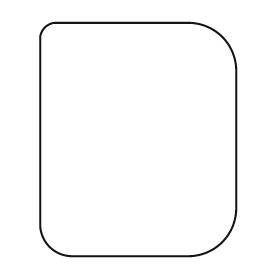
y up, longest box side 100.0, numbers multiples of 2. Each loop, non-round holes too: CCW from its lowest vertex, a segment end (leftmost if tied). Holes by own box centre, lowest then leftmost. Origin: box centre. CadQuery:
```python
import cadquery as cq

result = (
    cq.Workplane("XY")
    .moveTo(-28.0, -50.0)
    .lineTo(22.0, -50.0)
    .threePointArc((36.0, -44.0), (42.0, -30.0))
    .lineTo(42.0, 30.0)
    .threePointArc((36.0, 44.0), (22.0, 50.0))
    .lineTo(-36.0, 50.0)
    .threePointArc((-40.0, 48.0), (-42.0, 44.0))
    .lineTo(-42.0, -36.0)
    .threePointArc((-38.0, -46.0), (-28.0, -50.0))
    .close()
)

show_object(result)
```